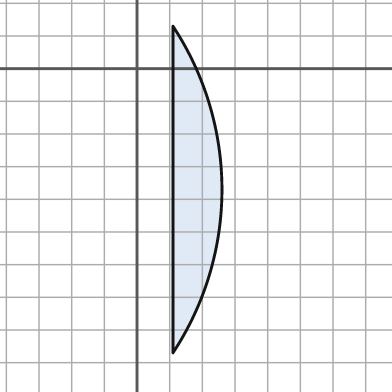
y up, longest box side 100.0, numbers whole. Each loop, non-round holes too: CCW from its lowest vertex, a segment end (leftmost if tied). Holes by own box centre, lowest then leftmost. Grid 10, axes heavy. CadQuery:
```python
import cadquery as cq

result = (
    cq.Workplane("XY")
    .moveTo(11.0, -87.0)
    .threePointArc((26.0, -37.0), (11.0, 13.0))
    .close()
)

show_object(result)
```